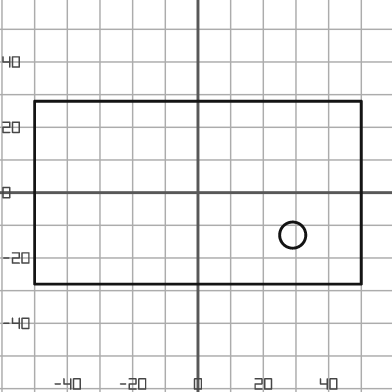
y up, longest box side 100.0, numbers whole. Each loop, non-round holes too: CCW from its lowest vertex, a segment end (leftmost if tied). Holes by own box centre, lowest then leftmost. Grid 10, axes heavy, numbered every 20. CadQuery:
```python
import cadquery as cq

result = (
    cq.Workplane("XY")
    .moveTo(-50.0, -28.0)
    .lineTo(50.0, -28.0)
    .lineTo(50.0, 28.0)
    .lineTo(-50.0, 28.0)
    .close()
    .moveTo(29.0, -13.0)
    .circle(4.0)
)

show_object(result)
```